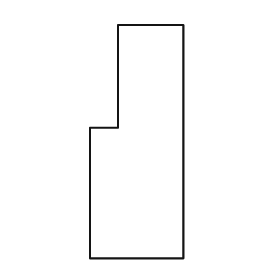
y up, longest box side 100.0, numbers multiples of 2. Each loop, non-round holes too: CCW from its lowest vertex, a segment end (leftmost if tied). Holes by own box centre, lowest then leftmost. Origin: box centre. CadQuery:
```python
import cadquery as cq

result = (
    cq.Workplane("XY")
    .moveTo(-20.0, -50.0)
    .lineTo(20.0, -50.0)
    .lineTo(20.0, 50.0)
    .lineTo(-8.0, 50.0)
    .lineTo(-8.0, 6.0)
    .lineTo(-20.0, 6.0)
    .close()
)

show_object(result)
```